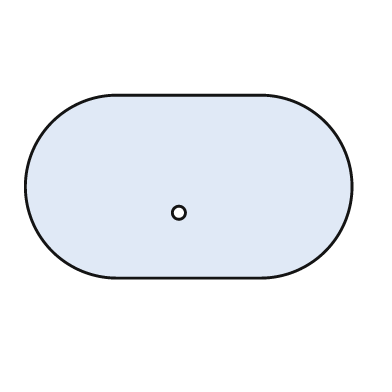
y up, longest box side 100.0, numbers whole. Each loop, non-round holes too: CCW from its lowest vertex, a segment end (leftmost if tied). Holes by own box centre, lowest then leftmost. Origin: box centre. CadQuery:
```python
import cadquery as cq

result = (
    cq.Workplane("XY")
    .moveTo(-22.0, -28.0)
    .lineTo(22.0, -28.0)
    .threePointArc((50.0, 0.0), (22.0, 28.0))
    .lineTo(-22.0, 28.0)
    .threePointArc((-50.0, 0.0), (-22.0, -28.0))
    .close()
    .moveTo(-3.0, -8.0)
    .circle(2.0)
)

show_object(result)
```